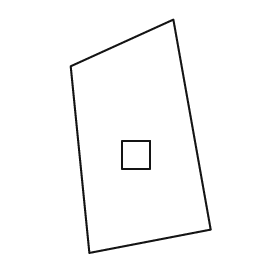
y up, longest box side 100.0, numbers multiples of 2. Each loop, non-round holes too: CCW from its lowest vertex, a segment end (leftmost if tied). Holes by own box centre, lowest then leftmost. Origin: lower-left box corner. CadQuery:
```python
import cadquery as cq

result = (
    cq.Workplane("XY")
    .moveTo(8.0, 0.0)
    .lineTo(60.0, 10.0)
    .lineTo(44.0, 100.0)
    .lineTo(0.0, 80.0)
    .close()
    .moveTo(22.0, 36.0)
    .lineTo(34.0, 36.0)
    .lineTo(34.0, 48.0)
    .lineTo(22.0, 48.0)
    .close()
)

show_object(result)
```